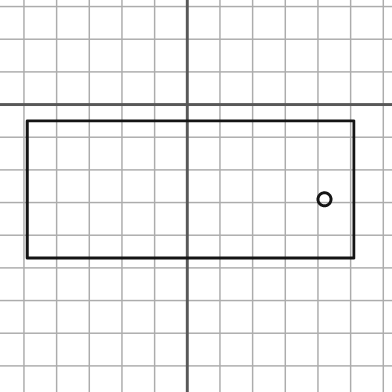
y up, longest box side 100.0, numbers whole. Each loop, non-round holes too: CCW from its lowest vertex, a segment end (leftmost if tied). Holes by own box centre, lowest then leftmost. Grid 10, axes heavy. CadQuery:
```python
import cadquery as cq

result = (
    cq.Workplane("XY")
    .moveTo(-49.0, -47.0)
    .lineTo(51.0, -47.0)
    .lineTo(51.0, -5.0)
    .lineTo(-49.0, -5.0)
    .close()
    .moveTo(42.0, -29.0)
    .circle(2.0)
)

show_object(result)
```